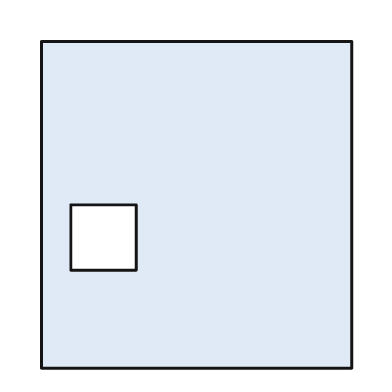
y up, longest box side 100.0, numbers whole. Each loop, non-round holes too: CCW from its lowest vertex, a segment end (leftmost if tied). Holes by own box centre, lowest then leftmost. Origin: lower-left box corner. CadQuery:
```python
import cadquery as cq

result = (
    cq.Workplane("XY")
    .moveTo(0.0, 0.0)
    .lineTo(95.0, 0.0)
    .lineTo(95.0, 100.0)
    .lineTo(0.0, 100.0)
    .close()
    .moveTo(9.0, 30.0)
    .lineTo(29.0, 30.0)
    .lineTo(29.0, 50.0)
    .lineTo(9.0, 50.0)
    .close()
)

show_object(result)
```